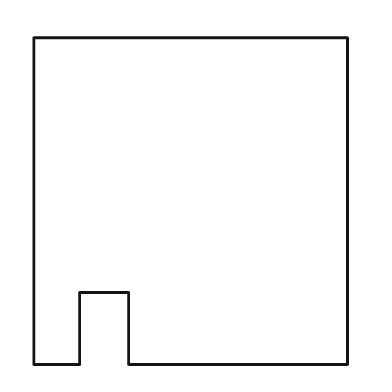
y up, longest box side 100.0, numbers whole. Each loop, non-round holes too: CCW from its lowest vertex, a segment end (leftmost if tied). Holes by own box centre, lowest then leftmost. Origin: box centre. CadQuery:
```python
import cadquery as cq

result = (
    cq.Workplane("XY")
    .moveTo(-48.0, -50.0)
    .lineTo(-34.0, -50.0)
    .lineTo(-34.0, -28.0)
    .lineTo(-19.0, -28.0)
    .lineTo(-19.0, -50.0)
    .lineTo(48.0, -50.0)
    .lineTo(48.0, 50.0)
    .lineTo(-48.0, 50.0)
    .close()
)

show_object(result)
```